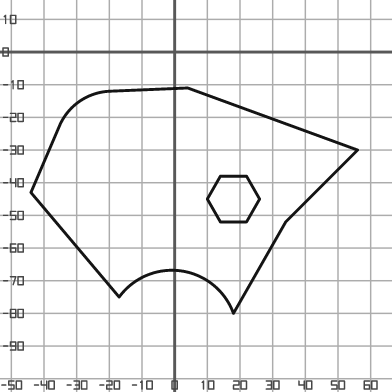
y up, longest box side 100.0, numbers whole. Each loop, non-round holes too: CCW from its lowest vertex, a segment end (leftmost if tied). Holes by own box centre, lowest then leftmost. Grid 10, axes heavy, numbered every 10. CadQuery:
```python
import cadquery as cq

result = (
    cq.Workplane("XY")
    .moveTo(18.0, -80.0)
    .lineTo(34.0, -52.0)
    .lineTo(56.0, -30.0)
    .lineTo(4.0, -11.0)
    .lineTo(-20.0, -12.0)
    .threePointArc((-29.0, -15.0), (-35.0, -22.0))
    .lineTo(-44.0, -43.0)
    .lineTo(-17.0, -75.0)
    .threePointArc((2.0, -67.0), (18.0, -80.0))
    .close()
    .moveTo(14.0, -52.0)
    .lineTo(22.0, -52.0)
    .lineTo(26.0, -45.0)
    .lineTo(22.0, -38.0)
    .lineTo(14.0, -38.0)
    .lineTo(10.0, -45.0)
    .close()
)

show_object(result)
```